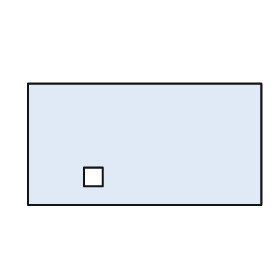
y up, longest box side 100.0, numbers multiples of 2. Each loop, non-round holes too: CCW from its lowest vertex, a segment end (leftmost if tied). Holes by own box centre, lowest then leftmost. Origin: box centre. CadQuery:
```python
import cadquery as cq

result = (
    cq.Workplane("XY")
    .moveTo(-50.0, -26.0)
    .lineTo(50.0, -26.0)
    .lineTo(50.0, 26.0)
    .lineTo(-50.0, 26.0)
    .close()
    .moveTo(-26.0, -18.0)
    .lineTo(-18.0, -18.0)
    .lineTo(-18.0, -10.0)
    .lineTo(-26.0, -10.0)
    .close()
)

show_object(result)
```